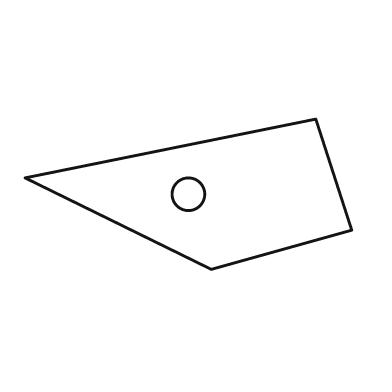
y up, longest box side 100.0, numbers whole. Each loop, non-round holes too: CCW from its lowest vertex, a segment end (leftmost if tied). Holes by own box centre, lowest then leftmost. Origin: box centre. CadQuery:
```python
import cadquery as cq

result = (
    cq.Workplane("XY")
    .moveTo(7.0, -23.0)
    .lineTo(50.0, -11.0)
    .lineTo(39.0, 23.0)
    .lineTo(-50.0, 5.0)
    .close()
    .moveTo(0.0, 0.0)
    .circle(5.0)
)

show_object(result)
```